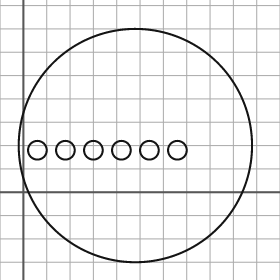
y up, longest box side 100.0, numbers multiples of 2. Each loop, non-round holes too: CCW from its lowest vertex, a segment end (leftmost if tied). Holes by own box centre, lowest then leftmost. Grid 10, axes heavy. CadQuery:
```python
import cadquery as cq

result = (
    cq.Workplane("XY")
    .moveTo(48.0, 20.0)
    .circle(50.0)
    .moveTo(6.0, 18.0)
    .circle(4.0)
    .moveTo(18.0, 18.0)
    .circle(4.0)
    .moveTo(30.0, 18.0)
    .circle(4.0)
    .moveTo(42.0, 18.0)
    .circle(4.0)
    .moveTo(54.0, 18.0)
    .circle(4.0)
    .moveTo(66.0, 18.0)
    .circle(4.0)
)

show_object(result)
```